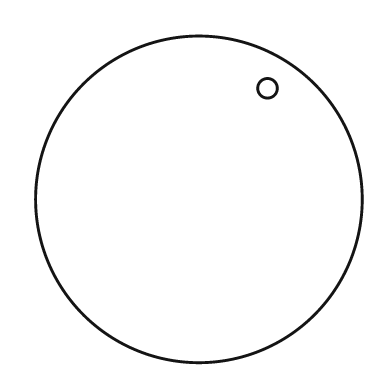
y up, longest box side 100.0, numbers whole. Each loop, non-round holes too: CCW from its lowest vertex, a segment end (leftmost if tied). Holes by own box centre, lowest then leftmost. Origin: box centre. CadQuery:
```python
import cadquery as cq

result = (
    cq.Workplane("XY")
    .moveTo(0.0, 0.0)
    .circle(50.0)
    .moveTo(21.0, 34.0)
    .circle(3.0)
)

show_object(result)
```